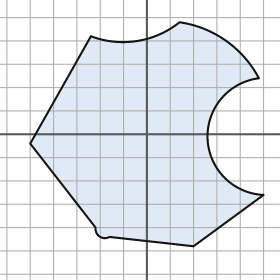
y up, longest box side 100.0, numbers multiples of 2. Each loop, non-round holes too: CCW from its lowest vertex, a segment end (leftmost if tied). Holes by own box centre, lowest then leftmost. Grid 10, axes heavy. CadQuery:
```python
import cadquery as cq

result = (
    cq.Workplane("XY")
    .moveTo(20.0, -48.0)
    .lineTo(50.0, -26.0)
    .threePointArc((26.0, -2.0), (48.0, 24.0))
    .threePointArc((34.0, 40.0), (14.0, 48.0))
    .threePointArc((-4.0, 40.0), (-24.0, 42.0))
    .lineTo(-50.0, -4.0)
    .lineTo(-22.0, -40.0)
    .threePointArc((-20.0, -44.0), (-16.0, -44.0))
    .close()
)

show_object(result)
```